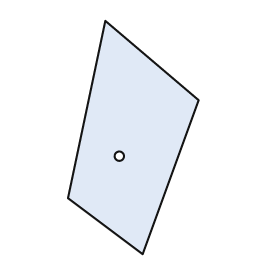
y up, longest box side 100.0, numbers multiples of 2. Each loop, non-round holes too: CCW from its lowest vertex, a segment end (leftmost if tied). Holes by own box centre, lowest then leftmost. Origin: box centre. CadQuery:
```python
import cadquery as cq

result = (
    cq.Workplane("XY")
    .moveTo(4.0, -50.0)
    .lineTo(28.0, 16.0)
    .lineTo(-12.0, 50.0)
    .lineTo(-28.0, -26.0)
    .close()
    .moveTo(-6.0, -8.0)
    .circle(2.0)
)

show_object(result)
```